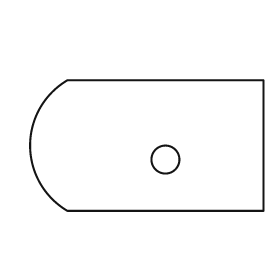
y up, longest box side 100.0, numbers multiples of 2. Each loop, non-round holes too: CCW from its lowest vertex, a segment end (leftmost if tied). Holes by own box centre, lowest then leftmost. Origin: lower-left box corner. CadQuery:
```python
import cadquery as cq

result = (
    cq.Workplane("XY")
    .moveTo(16.0, 0.0)
    .lineTo(100.0, 0.0)
    .lineTo(100.0, 56.0)
    .lineTo(16.0, 56.0)
    .threePointArc((0.0, 28.0), (16.0, 0.0))
    .close()
    .moveTo(58.0, 22.0)
    .circle(6.0)
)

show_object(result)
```